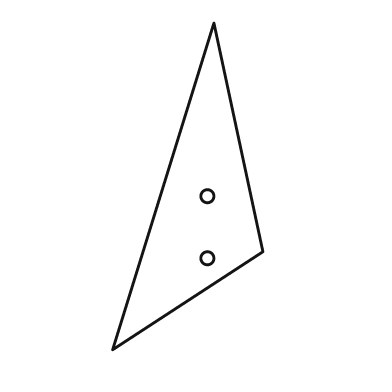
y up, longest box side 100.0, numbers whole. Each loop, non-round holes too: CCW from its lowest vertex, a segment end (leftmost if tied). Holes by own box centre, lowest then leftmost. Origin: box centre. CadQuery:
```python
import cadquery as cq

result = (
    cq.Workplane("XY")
    .moveTo(-23.0, -50.0)
    .lineTo(23.0, -20.0)
    .lineTo(8.0, 50.0)
    .close()
    .moveTo(6.0, -22.0)
    .circle(2.0)
    .moveTo(6.0, -3.0)
    .circle(2.0)
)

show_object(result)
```